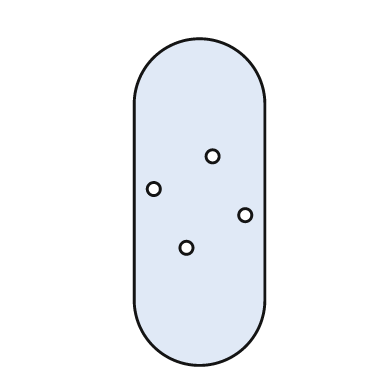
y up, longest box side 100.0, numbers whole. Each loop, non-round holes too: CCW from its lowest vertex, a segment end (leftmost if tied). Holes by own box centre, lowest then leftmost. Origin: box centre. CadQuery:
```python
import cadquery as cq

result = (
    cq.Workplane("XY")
    .moveTo(-20.0, -30.0)
    .threePointArc((0.0, -50.0), (20.0, -30.0))
    .lineTo(20.0, 30.0)
    .threePointArc((0.0, 50.0), (-20.0, 30.0))
    .close()
    .moveTo(-4.0, -14.0)
    .circle(2.0)
    .moveTo(14.0, -4.0)
    .circle(2.0)
    .moveTo(-14.0, 4.0)
    .circle(2.0)
    .moveTo(4.0, 14.0)
    .circle(2.0)
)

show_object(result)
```